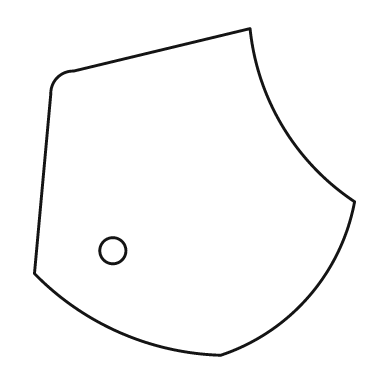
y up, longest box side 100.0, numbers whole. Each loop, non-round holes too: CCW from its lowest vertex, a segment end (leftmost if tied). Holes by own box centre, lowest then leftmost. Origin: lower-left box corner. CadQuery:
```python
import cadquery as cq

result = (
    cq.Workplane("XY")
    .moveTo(57.0, 0.0)
    .threePointArc((84.0, 18.0), (98.0, 47.0))
    .threePointArc((76.0, 70.0), (66.0, 100.0))
    .lineTo(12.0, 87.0)
    .threePointArc((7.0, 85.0), (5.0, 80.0))
    .lineTo(0.0, 25.0)
    .threePointArc((26.0, 7.0), (57.0, 0.0))
    .close()
    .moveTo(24.0, 32.0)
    .circle(4.0)
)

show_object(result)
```